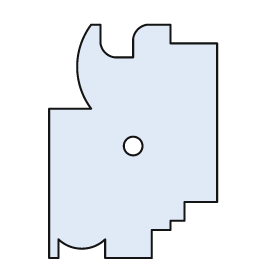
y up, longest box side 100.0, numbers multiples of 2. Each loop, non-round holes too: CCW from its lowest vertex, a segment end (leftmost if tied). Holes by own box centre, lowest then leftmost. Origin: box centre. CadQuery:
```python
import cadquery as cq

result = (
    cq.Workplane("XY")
    .moveTo(-36.0, -50.0)
    .lineTo(-32.0, -50.0)
    .lineTo(-32.0, -42.0)
    .threePointArc((-22.0, -46.0), (-12.0, -42.0))
    .lineTo(-12.0, -50.0)
    .lineTo(8.0, -50.0)
    .lineTo(8.0, -38.0)
    .lineTo(16.0, -38.0)
    .lineTo(16.0, -34.0)
    .lineTo(22.0, -34.0)
    .lineTo(22.0, -26.0)
    .lineTo(36.0, -26.0)
    .lineTo(36.0, 42.0)
    .lineTo(16.0, 42.0)
    .lineTo(16.0, 50.0)
    .lineTo(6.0, 50.0)
    .threePointArc((2.0, 48.0), (0.0, 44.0))
    .lineTo(0.0, 36.0)
    .lineTo(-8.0, 36.0)
    .threePointArc((-12.0, 38.0), (-14.0, 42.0))
    .lineTo(-14.0, 50.0)
    .lineTo(-18.0, 50.0)
    .threePointArc((-24.0, 32.0), (-18.0, 14.0))
    .lineTo(-36.0, 14.0)
    .close()
    .moveTo(0.0, -2.0)
    .circle(4.0)
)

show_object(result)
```